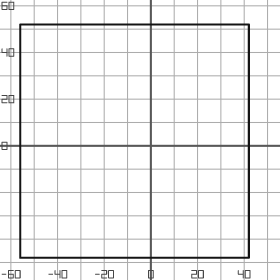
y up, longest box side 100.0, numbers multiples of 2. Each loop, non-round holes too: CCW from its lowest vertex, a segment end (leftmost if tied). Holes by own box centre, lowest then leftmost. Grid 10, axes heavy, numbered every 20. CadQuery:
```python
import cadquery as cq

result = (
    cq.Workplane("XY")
    .moveTo(-56.0, -48.0)
    .lineTo(42.0, -48.0)
    .lineTo(42.0, 52.0)
    .lineTo(-56.0, 52.0)
    .close()
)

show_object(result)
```